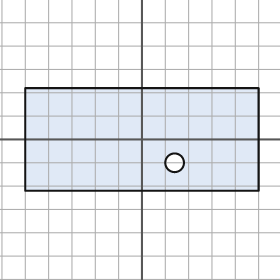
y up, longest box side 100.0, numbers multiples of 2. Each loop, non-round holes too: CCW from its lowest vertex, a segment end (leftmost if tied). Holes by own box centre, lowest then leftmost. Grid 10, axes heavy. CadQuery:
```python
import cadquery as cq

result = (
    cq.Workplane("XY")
    .moveTo(-50.0, -22.0)
    .lineTo(50.0, -22.0)
    .lineTo(50.0, 22.0)
    .lineTo(-50.0, 22.0)
    .close()
    .moveTo(14.0, -10.0)
    .circle(4.0)
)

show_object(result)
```